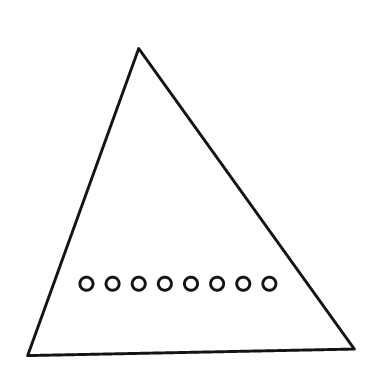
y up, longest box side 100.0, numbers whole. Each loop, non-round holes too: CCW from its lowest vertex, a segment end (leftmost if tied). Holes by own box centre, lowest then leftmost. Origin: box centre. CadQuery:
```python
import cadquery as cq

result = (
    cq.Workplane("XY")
    .moveTo(-50.0, -47.0)
    .lineTo(50.0, -45.0)
    .lineTo(-16.0, 47.0)
    .close()
    .moveTo(-32.0, -25.0)
    .circle(2.0)
    .moveTo(-24.0, -25.0)
    .circle(2.0)
    .moveTo(-16.0, -25.0)
    .circle(2.0)
    .moveTo(-8.0, -25.0)
    .circle(2.0)
    .moveTo(0.0, -25.0)
    .circle(2.0)
    .moveTo(8.0, -25.0)
    .circle(2.0)
    .moveTo(16.0, -25.0)
    .circle(2.0)
    .moveTo(24.0, -25.0)
    .circle(2.0)
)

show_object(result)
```